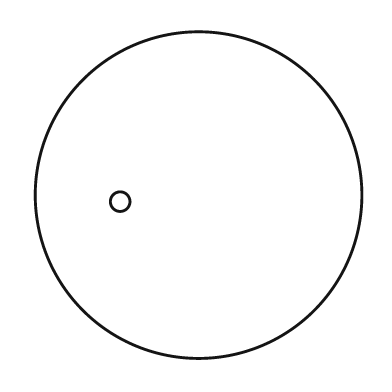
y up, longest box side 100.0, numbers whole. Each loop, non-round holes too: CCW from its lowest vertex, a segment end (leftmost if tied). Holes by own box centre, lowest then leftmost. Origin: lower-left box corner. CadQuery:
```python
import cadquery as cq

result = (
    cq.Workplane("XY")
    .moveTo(50.0, 50.0)
    .circle(50.0)
    .moveTo(26.0, 48.0)
    .circle(3.0)
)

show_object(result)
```